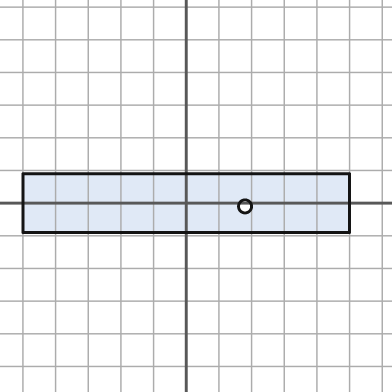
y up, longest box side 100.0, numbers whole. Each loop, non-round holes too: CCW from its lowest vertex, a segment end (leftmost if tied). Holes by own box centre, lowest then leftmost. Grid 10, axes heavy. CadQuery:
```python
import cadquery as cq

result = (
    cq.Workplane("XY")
    .moveTo(-50.0, -9.0)
    .lineTo(50.0, -9.0)
    .lineTo(50.0, 9.0)
    .lineTo(-50.0, 9.0)
    .close()
    .moveTo(18.0, -1.0)
    .circle(2.0)
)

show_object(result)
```